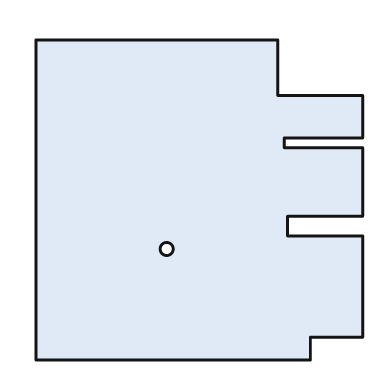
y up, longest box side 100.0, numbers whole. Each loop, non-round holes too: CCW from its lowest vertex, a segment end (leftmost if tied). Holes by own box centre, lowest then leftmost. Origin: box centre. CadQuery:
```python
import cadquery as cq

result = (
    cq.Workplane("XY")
    .moveTo(-50.0, -49.0)
    .lineTo(34.0, -49.0)
    .lineTo(34.0, -42.0)
    .lineTo(50.0, -42.0)
    .lineTo(50.0, -11.0)
    .lineTo(27.0, -11.0)
    .lineTo(27.0, -5.0)
    .lineTo(50.0, -5.0)
    .lineTo(50.0, 16.0)
    .lineTo(26.0, 16.0)
    .lineTo(26.0, 19.0)
    .lineTo(50.0, 19.0)
    .lineTo(50.0, 32.0)
    .lineTo(24.0, 32.0)
    .lineTo(24.0, 49.0)
    .lineTo(-50.0, 49.0)
    .close()
    .moveTo(-10.0, -15.0)
    .circle(2.0)
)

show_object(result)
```